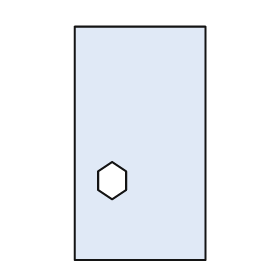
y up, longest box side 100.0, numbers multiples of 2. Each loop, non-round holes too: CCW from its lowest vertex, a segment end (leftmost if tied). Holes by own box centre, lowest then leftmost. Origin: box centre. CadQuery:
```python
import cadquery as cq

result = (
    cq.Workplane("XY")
    .moveTo(-28.0, -50.0)
    .lineTo(28.0, -50.0)
    .lineTo(28.0, 50.0)
    .lineTo(-28.0, 50.0)
    .close()
    .moveTo(-12.0, -24.0)
    .lineTo(-6.0, -20.0)
    .lineTo(-6.0, -12.0)
    .lineTo(-12.0, -8.0)
    .lineTo(-18.0, -12.0)
    .lineTo(-18.0, -20.0)
    .close()
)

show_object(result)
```